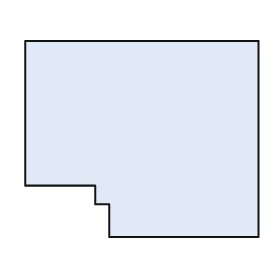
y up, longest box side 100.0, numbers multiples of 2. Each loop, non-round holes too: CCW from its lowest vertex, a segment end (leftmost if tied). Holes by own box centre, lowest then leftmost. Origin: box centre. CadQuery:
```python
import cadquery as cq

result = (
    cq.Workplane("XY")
    .moveTo(-14.0, -42.0)
    .lineTo(50.0, -42.0)
    .lineTo(50.0, 42.0)
    .lineTo(-50.0, 42.0)
    .lineTo(-50.0, -20.0)
    .lineTo(-20.0, -20.0)
    .lineTo(-20.0, -28.0)
    .lineTo(-14.0, -28.0)
    .close()
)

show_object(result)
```